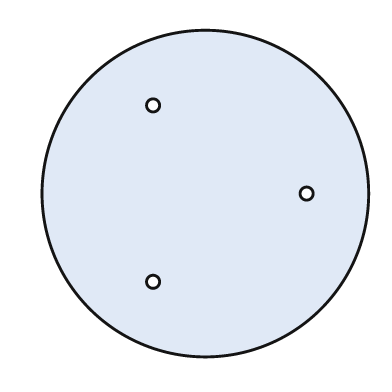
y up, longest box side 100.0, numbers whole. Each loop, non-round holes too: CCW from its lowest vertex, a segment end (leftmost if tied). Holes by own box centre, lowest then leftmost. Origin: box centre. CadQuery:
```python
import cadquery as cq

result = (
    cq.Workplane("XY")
    .moveTo(0.0, 0.0)
    .circle(50.0)
    .moveTo(-16.0, -27.0)
    .circle(2.0)
    .moveTo(31.0, 0.0)
    .circle(2.0)
    .moveTo(-16.0, 27.0)
    .circle(2.0)
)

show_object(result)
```